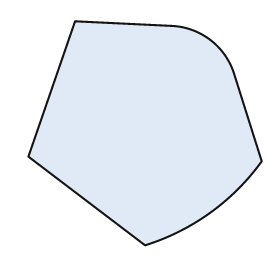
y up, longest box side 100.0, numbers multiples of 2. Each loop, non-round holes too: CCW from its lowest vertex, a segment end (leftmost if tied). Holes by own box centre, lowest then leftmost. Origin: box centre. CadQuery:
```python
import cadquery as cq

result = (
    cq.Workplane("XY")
    .moveTo(0.0, -48.0)
    .threePointArc((28.0, -34.0), (50.0, -12.0))
    .lineTo(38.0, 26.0)
    .threePointArc((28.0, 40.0), (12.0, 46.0))
    .lineTo(-30.0, 48.0)
    .lineTo(-50.0, -10.0)
    .close()
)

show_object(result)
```